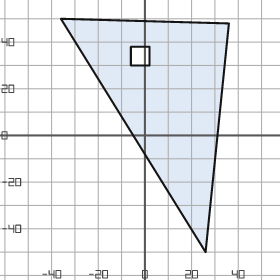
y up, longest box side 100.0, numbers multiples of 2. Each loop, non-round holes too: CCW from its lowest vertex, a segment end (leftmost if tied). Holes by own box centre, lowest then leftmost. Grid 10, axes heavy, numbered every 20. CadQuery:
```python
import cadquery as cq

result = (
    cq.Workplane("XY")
    .moveTo(26.0, -50.0)
    .lineTo(36.0, 48.0)
    .lineTo(-36.0, 50.0)
    .close()
    .moveTo(-6.0, 30.0)
    .lineTo(2.0, 30.0)
    .lineTo(2.0, 38.0)
    .lineTo(-6.0, 38.0)
    .close()
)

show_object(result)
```